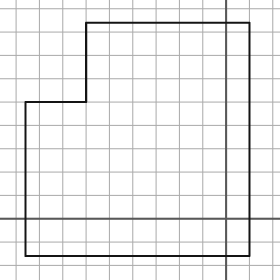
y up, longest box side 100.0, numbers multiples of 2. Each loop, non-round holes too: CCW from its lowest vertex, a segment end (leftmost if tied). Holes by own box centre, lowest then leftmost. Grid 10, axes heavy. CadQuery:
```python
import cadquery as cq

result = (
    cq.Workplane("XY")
    .moveTo(-86.0, -16.0)
    .lineTo(10.0, -16.0)
    .lineTo(10.0, 84.0)
    .lineTo(-60.0, 84.0)
    .lineTo(-60.0, 50.0)
    .lineTo(-86.0, 50.0)
    .close()
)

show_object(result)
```